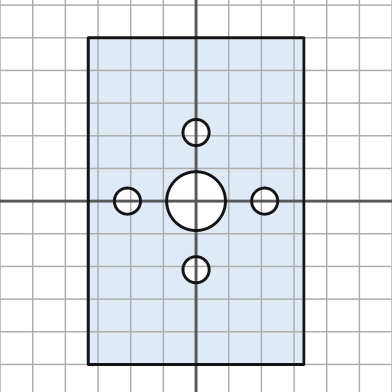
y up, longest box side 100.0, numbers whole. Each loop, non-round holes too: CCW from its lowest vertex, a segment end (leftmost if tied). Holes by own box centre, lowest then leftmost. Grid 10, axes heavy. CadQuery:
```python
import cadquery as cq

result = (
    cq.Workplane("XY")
    .moveTo(-33.0, -50.0)
    .lineTo(33.0, -50.0)
    .lineTo(33.0, 50.0)
    .lineTo(-33.0, 50.0)
    .close()
    .moveTo(0.0, -21.0)
    .circle(4.0)
    .moveTo(-21.0, 0.0)
    .circle(4.0)
    .moveTo(0.0, 0.0)
    .circle(9.0)
    .moveTo(21.0, 0.0)
    .circle(4.0)
    .moveTo(0.0, 21.0)
    .circle(4.0)
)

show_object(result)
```